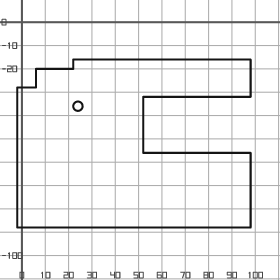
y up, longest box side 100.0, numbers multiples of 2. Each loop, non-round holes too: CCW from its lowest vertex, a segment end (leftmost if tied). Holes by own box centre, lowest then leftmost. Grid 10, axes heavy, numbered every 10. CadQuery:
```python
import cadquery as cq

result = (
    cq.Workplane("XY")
    .moveTo(-2.0, -88.0)
    .lineTo(98.0, -88.0)
    .lineTo(98.0, -56.0)
    .lineTo(52.0, -56.0)
    .lineTo(52.0, -32.0)
    .lineTo(98.0, -32.0)
    .lineTo(98.0, -16.0)
    .lineTo(22.0, -16.0)
    .lineTo(22.0, -20.0)
    .lineTo(6.0, -20.0)
    .lineTo(6.0, -28.0)
    .lineTo(-2.0, -28.0)
    .close()
    .moveTo(24.0, -36.0)
    .circle(2.0)
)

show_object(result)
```